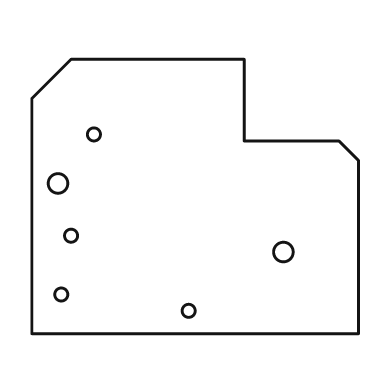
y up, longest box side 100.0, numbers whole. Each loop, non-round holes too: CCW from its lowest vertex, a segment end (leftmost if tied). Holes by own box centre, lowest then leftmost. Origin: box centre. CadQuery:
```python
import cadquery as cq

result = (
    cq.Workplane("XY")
    .moveTo(-50.0, -42.0)
    .lineTo(50.0, -42.0)
    .lineTo(50.0, 11.0)
    .lineTo(44.0, 17.0)
    .lineTo(15.0, 17.0)
    .lineTo(15.0, 42.0)
    .lineTo(-38.0, 42.0)
    .lineTo(-50.0, 30.0)
    .close()
    .moveTo(-2.0, -35.0)
    .circle(2.0)
    .moveTo(-41.0, -30.0)
    .circle(2.0)
    .moveTo(27.0, -17.0)
    .circle(3.0)
    .moveTo(-38.0, -12.0)
    .circle(2.0)
    .moveTo(-42.0, 4.0)
    .circle(3.0)
    .moveTo(-31.0, 19.0)
    .circle(2.0)
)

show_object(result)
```